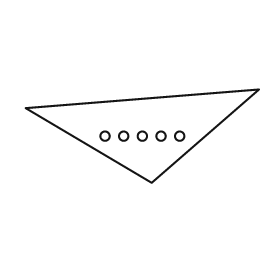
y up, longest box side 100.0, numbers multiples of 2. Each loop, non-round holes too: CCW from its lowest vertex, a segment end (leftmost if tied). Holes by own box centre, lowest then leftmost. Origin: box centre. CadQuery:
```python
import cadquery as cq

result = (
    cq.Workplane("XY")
    .moveTo(4.0, -20.0)
    .lineTo(50.0, 20.0)
    .lineTo(-50.0, 12.0)
    .close()
    .moveTo(-16.0, 0.0)
    .circle(2.0)
    .moveTo(-8.0, 0.0)
    .circle(2.0)
    .moveTo(0.0, 0.0)
    .circle(2.0)
    .moveTo(8.0, 0.0)
    .circle(2.0)
    .moveTo(16.0, 0.0)
    .circle(2.0)
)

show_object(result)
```